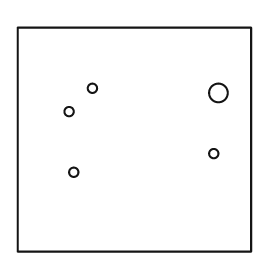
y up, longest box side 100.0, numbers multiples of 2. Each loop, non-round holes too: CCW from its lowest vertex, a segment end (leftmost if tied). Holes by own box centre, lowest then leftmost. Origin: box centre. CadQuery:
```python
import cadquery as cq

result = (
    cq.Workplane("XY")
    .moveTo(-50.0, -48.0)
    .lineTo(50.0, -48.0)
    .lineTo(50.0, 48.0)
    .lineTo(-50.0, 48.0)
    .close()
    .moveTo(-26.0, -14.0)
    .circle(2.0)
    .moveTo(34.0, -6.0)
    .circle(2.0)
    .moveTo(-28.0, 12.0)
    .circle(2.0)
    .moveTo(36.0, 20.0)
    .circle(4.0)
    .moveTo(-18.0, 22.0)
    .circle(2.0)
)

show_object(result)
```